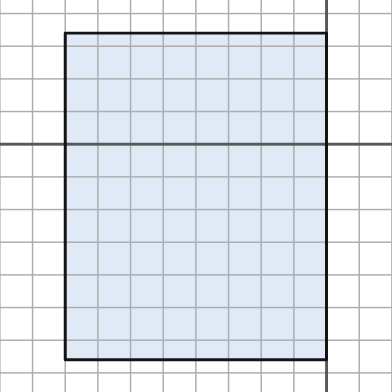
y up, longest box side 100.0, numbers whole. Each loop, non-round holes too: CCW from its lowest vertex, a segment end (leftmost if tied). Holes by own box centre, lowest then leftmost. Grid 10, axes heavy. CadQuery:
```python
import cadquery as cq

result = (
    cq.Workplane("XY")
    .moveTo(-80.0, -66.0)
    .lineTo(0.0, -66.0)
    .lineTo(0.0, 34.0)
    .lineTo(-80.0, 34.0)
    .close()
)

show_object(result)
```